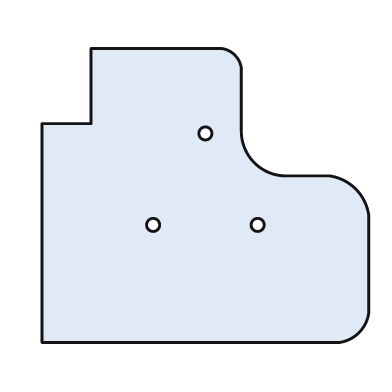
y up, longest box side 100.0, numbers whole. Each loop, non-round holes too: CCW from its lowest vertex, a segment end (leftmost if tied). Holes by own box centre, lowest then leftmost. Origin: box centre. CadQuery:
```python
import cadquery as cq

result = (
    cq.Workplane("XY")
    .moveTo(-50.0, -45.0)
    .lineTo(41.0, -45.0)
    .threePointArc((47.0, -42.0), (50.0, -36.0))
    .lineTo(50.0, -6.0)
    .threePointArc((46.0, 2.0), (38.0, 6.0))
    .lineTo(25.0, 6.0)
    .threePointArc((15.0, 10.0), (11.0, 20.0))
    .lineTo(11.0, 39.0)
    .threePointArc((9.0, 43.0), (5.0, 45.0))
    .lineTo(-35.0, 45.0)
    .lineTo(-35.0, 22.0)
    .lineTo(-50.0, 22.0)
    .close()
    .moveTo(-16.0, -9.0)
    .circle(2.0)
    .moveTo(16.0, -9.0)
    .circle(2.0)
    .moveTo(0.0, 19.0)
    .circle(2.0)
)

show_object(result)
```